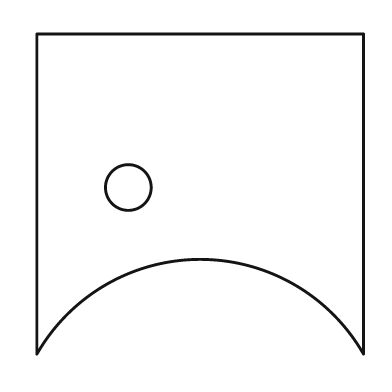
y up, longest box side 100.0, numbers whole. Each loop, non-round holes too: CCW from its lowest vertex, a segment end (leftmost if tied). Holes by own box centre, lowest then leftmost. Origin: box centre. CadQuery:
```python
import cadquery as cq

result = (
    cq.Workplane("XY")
    .moveTo(-50.0, -49.0)
    .threePointArc((0.0, -20.0), (50.0, -49.0))
    .lineTo(50.0, 49.0)
    .lineTo(-50.0, 49.0)
    .close()
    .moveTo(-22.0, 2.0)
    .circle(7.0)
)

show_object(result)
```